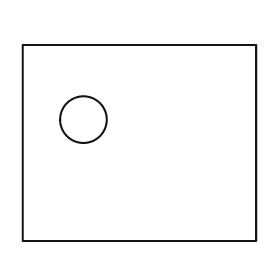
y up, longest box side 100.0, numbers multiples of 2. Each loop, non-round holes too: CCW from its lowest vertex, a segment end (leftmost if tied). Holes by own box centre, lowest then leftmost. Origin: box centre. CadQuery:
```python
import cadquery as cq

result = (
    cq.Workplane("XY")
    .moveTo(-50.0, -42.0)
    .lineTo(50.0, -42.0)
    .lineTo(50.0, 42.0)
    .lineTo(-50.0, 42.0)
    .close()
    .moveTo(-24.0, 10.0)
    .circle(10.0)
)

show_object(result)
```